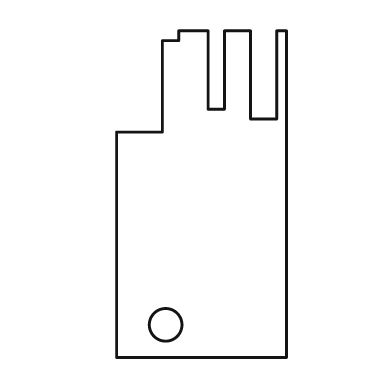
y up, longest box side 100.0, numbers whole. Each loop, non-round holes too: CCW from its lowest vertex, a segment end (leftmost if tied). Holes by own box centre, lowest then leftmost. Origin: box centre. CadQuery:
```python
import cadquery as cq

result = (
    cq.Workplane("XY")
    .moveTo(-26.0, -50.0)
    .lineTo(26.0, -50.0)
    .lineTo(26.0, 50.0)
    .lineTo(23.0, 50.0)
    .lineTo(23.0, 23.0)
    .lineTo(15.0, 23.0)
    .lineTo(15.0, 50.0)
    .lineTo(7.0, 50.0)
    .lineTo(7.0, 26.0)
    .lineTo(2.0, 26.0)
    .lineTo(2.0, 50.0)
    .lineTo(-7.0, 50.0)
    .lineTo(-7.0, 47.0)
    .lineTo(-12.0, 47.0)
    .lineTo(-12.0, 19.0)
    .lineTo(-26.0, 19.0)
    .close()
    .moveTo(-11.0, -40.0)
    .circle(5.0)
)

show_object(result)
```